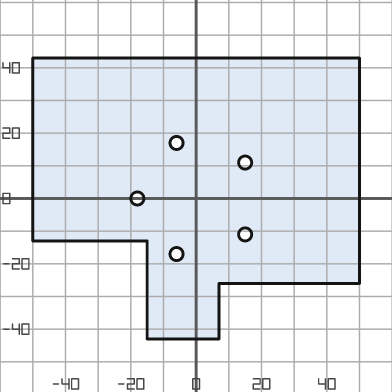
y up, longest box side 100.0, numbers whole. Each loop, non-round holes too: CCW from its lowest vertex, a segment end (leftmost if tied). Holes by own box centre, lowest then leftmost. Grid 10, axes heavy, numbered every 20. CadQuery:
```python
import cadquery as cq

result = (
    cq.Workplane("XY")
    .moveTo(-15.0, -43.0)
    .lineTo(7.0, -43.0)
    .lineTo(7.0, -26.0)
    .lineTo(50.0, -26.0)
    .lineTo(50.0, 43.0)
    .lineTo(-50.0, 43.0)
    .lineTo(-50.0, -13.0)
    .lineTo(-15.0, -13.0)
    .close()
    .moveTo(-6.0, -17.0)
    .circle(2.0)
    .moveTo(15.0, -11.0)
    .circle(2.0)
    .moveTo(-18.0, 0.0)
    .circle(2.0)
    .moveTo(15.0, 11.0)
    .circle(2.0)
    .moveTo(-6.0, 17.0)
    .circle(2.0)
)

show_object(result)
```